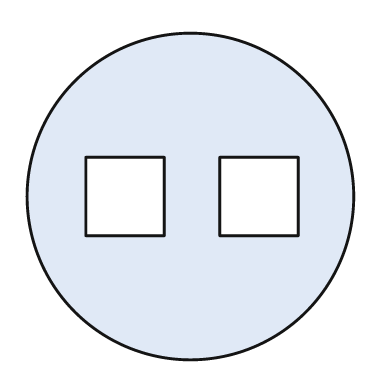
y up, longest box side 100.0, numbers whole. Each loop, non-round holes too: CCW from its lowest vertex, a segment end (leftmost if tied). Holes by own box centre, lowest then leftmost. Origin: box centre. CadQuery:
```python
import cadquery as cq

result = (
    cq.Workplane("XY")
    .moveTo(0.0, 0.0)
    .circle(50.0)
    .moveTo(-32.0, -12.0)
    .lineTo(-8.0, -12.0)
    .lineTo(-8.0, 12.0)
    .lineTo(-32.0, 12.0)
    .close()
    .moveTo(9.0, -12.0)
    .lineTo(33.0, -12.0)
    .lineTo(33.0, 12.0)
    .lineTo(9.0, 12.0)
    .close()
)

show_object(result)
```